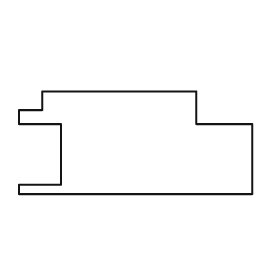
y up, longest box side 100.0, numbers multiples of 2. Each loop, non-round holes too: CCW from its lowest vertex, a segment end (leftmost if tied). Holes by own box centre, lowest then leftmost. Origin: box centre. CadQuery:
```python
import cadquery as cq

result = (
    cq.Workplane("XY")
    .moveTo(-50.0, -22.0)
    .lineTo(50.0, -22.0)
    .lineTo(50.0, 8.0)
    .lineTo(26.0, 8.0)
    .lineTo(26.0, 22.0)
    .lineTo(-40.0, 22.0)
    .lineTo(-40.0, 14.0)
    .lineTo(-50.0, 14.0)
    .lineTo(-50.0, 8.0)
    .lineTo(-32.0, 8.0)
    .lineTo(-32.0, -18.0)
    .lineTo(-50.0, -18.0)
    .close()
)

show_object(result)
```